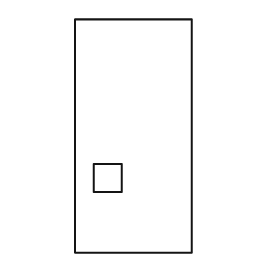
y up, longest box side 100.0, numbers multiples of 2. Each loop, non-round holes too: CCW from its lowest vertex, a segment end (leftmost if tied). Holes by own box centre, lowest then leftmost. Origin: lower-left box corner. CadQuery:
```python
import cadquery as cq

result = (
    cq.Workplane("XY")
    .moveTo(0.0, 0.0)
    .lineTo(50.0, 0.0)
    .lineTo(50.0, 100.0)
    .lineTo(0.0, 100.0)
    .close()
    .moveTo(8.0, 26.0)
    .lineTo(20.0, 26.0)
    .lineTo(20.0, 38.0)
    .lineTo(8.0, 38.0)
    .close()
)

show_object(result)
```